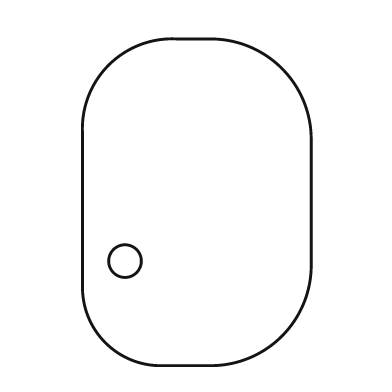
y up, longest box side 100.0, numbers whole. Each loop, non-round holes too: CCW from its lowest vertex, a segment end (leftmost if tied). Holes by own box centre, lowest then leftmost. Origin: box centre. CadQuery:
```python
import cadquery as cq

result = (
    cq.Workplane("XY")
    .moveTo(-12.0, -50.0)
    .lineTo(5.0, -50.0)
    .threePointArc((26.0, -41.0), (35.0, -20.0))
    .lineTo(35.0, 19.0)
    .threePointArc((26.0, 41.0), (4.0, 50.0))
    .lineTo(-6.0, 50.0)
    .threePointArc((-27.0, 42.0), (-35.0, 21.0))
    .lineTo(-35.0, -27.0)
    .threePointArc((-28.0, -43.0), (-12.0, -50.0))
    .close()
    .moveTo(-22.0, -18.0)
    .circle(5.0)
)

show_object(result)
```